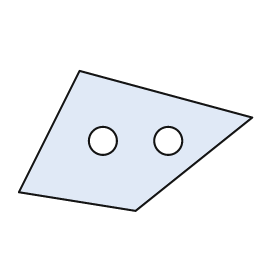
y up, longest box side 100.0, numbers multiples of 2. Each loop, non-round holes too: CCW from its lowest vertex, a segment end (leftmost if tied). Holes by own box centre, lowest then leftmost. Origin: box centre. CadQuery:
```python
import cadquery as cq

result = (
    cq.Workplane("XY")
    .moveTo(0.0, -30.0)
    .lineTo(50.0, 10.0)
    .lineTo(-24.0, 30.0)
    .lineTo(-50.0, -22.0)
    .close()
    .moveTo(-14.0, 0.0)
    .circle(6.0)
    .moveTo(14.0, 0.0)
    .circle(6.0)
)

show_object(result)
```